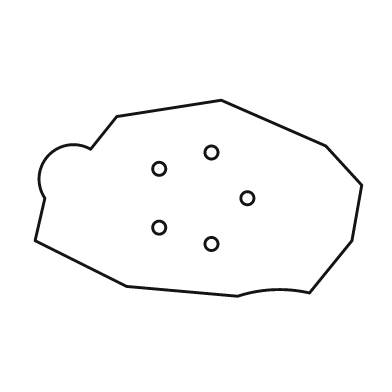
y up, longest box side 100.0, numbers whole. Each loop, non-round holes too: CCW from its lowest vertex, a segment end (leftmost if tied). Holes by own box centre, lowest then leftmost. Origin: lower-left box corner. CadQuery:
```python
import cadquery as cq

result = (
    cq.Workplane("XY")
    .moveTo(62.0, 0.0)
    .threePointArc((73.0, 2.0), (84.0, 1.0))
    .lineTo(97.0, 17.0)
    .lineTo(100.0, 34.0)
    .lineTo(89.0, 46.0)
    .lineTo(57.0, 60.0)
    .lineTo(25.0, 55.0)
    .lineTo(17.0, 45.0)
    .threePointArc((4.0, 43.0), (3.0, 30.0))
    .lineTo(0.0, 17.0)
    .lineTo(28.0, 3.0)
    .close()
    .moveTo(54.0, 16.0)
    .circle(2.0)
    .moveTo(38.0, 21.0)
    .circle(2.0)
    .moveTo(65.0, 30.0)
    .circle(2.0)
    .moveTo(38.0, 39.0)
    .circle(2.0)
    .moveTo(54.0, 44.0)
    .circle(2.0)
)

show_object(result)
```